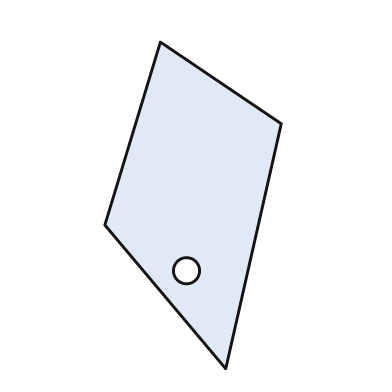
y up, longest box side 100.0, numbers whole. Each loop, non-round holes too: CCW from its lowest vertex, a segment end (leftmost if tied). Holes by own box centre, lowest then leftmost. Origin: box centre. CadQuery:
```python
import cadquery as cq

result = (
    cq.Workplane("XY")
    .moveTo(10.0, -50.0)
    .lineTo(27.0, 25.0)
    .lineTo(-10.0, 50.0)
    .lineTo(-27.0, -6.0)
    .close()
    .moveTo(-2.0, -20.0)
    .circle(4.0)
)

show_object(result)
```